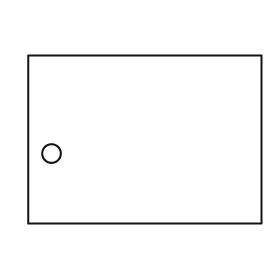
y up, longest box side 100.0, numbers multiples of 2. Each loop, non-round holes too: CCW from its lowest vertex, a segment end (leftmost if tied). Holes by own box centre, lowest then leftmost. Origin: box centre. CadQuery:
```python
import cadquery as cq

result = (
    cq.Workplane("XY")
    .moveTo(-50.0, -36.0)
    .lineTo(50.0, -36.0)
    .lineTo(50.0, 36.0)
    .lineTo(-50.0, 36.0)
    .close()
    .moveTo(-40.0, -6.0)
    .circle(4.0)
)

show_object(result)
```